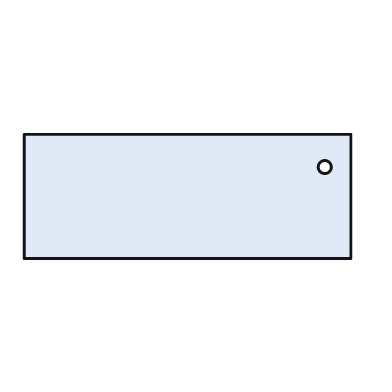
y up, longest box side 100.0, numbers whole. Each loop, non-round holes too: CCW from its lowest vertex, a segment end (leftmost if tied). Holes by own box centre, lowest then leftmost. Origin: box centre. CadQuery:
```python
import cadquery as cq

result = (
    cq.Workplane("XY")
    .moveTo(-50.0, -19.0)
    .lineTo(50.0, -19.0)
    .lineTo(50.0, 19.0)
    .lineTo(-50.0, 19.0)
    .close()
    .moveTo(42.0, 9.0)
    .circle(2.0)
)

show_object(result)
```